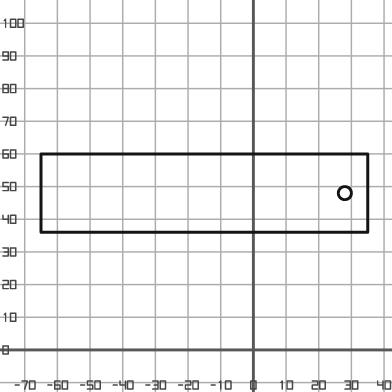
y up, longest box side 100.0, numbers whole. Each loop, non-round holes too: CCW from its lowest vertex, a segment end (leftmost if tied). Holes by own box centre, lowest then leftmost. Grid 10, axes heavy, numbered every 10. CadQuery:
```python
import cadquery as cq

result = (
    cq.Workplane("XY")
    .moveTo(-65.0, 36.0)
    .lineTo(35.0, 36.0)
    .lineTo(35.0, 60.0)
    .lineTo(-65.0, 60.0)
    .close()
    .moveTo(28.0, 48.0)
    .circle(2.0)
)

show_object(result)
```